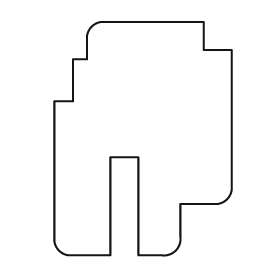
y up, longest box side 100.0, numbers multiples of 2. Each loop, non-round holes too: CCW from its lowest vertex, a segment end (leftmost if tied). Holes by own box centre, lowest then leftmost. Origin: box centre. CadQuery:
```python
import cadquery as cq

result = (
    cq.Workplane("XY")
    .moveTo(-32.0, -50.0)
    .lineTo(-14.0, -50.0)
    .lineTo(-14.0, -8.0)
    .lineTo(-2.0, -8.0)
    .lineTo(-2.0, -50.0)
    .lineTo(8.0, -50.0)
    .threePointArc((14.0, -48.0), (16.0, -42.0))
    .lineTo(16.0, -28.0)
    .lineTo(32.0, -28.0)
    .threePointArc((36.0, -26.0), (38.0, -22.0))
    .lineTo(38.0, 38.0)
    .lineTo(26.0, 38.0)
    .lineTo(26.0, 50.0)
    .lineTo(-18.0, 50.0)
    .threePointArc((-22.0, 48.0), (-24.0, 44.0))
    .lineTo(-24.0, 34.0)
    .lineTo(-30.0, 34.0)
    .lineTo(-30.0, 16.0)
    .lineTo(-38.0, 16.0)
    .lineTo(-38.0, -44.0)
    .threePointArc((-36.0, -48.0), (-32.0, -50.0))
    .close()
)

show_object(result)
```